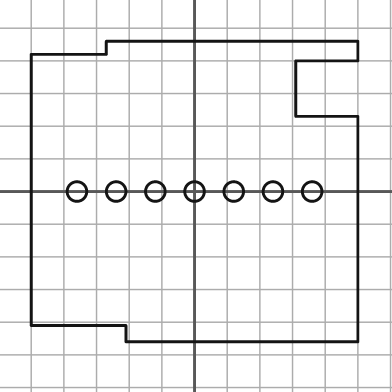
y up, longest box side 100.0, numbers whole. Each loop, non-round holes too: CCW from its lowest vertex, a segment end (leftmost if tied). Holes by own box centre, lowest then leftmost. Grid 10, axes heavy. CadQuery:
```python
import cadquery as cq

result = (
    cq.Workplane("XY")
    .moveTo(-21.0, -46.0)
    .lineTo(50.0, -46.0)
    .lineTo(50.0, 23.0)
    .lineTo(31.0, 23.0)
    .lineTo(31.0, 40.0)
    .lineTo(50.0, 40.0)
    .lineTo(50.0, 46.0)
    .lineTo(-27.0, 46.0)
    .lineTo(-27.0, 42.0)
    .lineTo(-50.0, 42.0)
    .lineTo(-50.0, -41.0)
    .lineTo(-21.0, -41.0)
    .close()
    .moveTo(-36.0, 0.0)
    .circle(3.0)
    .moveTo(-24.0, 0.0)
    .circle(3.0)
    .moveTo(-12.0, 0.0)
    .circle(3.0)
    .moveTo(0.0, 0.0)
    .circle(3.0)
    .moveTo(12.0, 0.0)
    .circle(3.0)
    .moveTo(24.0, 0.0)
    .circle(3.0)
    .moveTo(36.0, 0.0)
    .circle(3.0)
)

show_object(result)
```